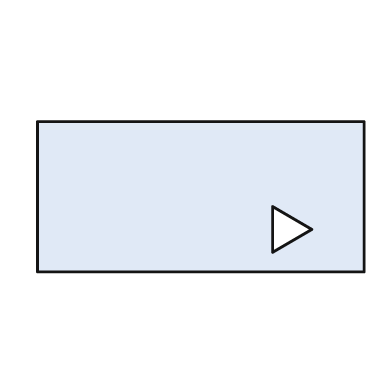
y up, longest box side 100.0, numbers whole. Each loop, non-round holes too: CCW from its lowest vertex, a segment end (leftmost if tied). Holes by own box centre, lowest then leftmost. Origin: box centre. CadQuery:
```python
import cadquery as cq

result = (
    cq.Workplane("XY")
    .moveTo(-50.0, -23.0)
    .lineTo(50.0, -23.0)
    .lineTo(50.0, 23.0)
    .lineTo(-50.0, 23.0)
    .close()
    .moveTo(22.0, -17.0)
    .lineTo(34.0, -10.0)
    .lineTo(22.0, -3.0)
    .close()
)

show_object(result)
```